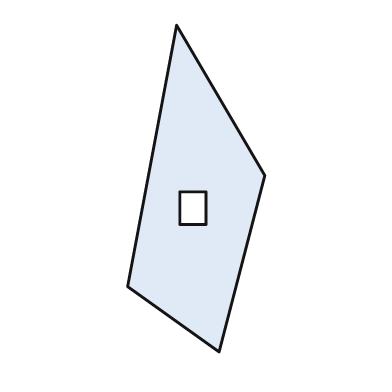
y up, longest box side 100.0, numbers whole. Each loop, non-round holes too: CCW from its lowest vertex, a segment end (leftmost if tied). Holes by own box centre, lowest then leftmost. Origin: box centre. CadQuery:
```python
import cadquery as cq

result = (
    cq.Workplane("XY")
    .moveTo(7.0, -50.0)
    .lineTo(21.0, 4.0)
    .lineTo(-6.0, 50.0)
    .lineTo(-21.0, -30.0)
    .close()
    .moveTo(-5.0, -11.0)
    .lineTo(3.0, -11.0)
    .lineTo(3.0, -1.0)
    .lineTo(-5.0, -1.0)
    .close()
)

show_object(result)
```